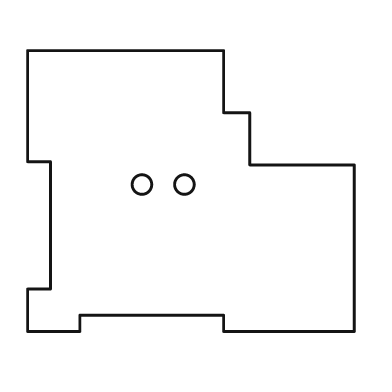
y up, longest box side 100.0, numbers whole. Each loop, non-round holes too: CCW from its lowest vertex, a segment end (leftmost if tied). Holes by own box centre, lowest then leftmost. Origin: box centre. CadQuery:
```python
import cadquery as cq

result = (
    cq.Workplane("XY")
    .moveTo(-50.0, -43.0)
    .lineTo(-34.0, -43.0)
    .lineTo(-34.0, -38.0)
    .lineTo(10.0, -38.0)
    .lineTo(10.0, -43.0)
    .lineTo(50.0, -43.0)
    .lineTo(50.0, 8.0)
    .lineTo(18.0, 8.0)
    .lineTo(18.0, 24.0)
    .lineTo(10.0, 24.0)
    .lineTo(10.0, 43.0)
    .lineTo(-50.0, 43.0)
    .lineTo(-50.0, 9.0)
    .lineTo(-43.0, 9.0)
    .lineTo(-43.0, -30.0)
    .lineTo(-50.0, -30.0)
    .close()
    .moveTo(-15.0, 2.0)
    .circle(3.0)
    .moveTo(-2.0, 2.0)
    .circle(3.0)
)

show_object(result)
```